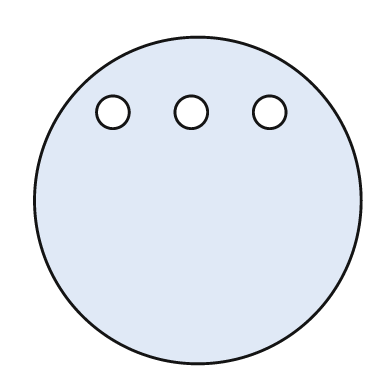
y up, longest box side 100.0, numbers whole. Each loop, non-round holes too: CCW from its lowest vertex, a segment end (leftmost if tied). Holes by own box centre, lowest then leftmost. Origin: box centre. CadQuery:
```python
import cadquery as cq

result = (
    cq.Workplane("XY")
    .moveTo(0.0, 0.0)
    .circle(50.0)
    .moveTo(-26.0, 27.0)
    .circle(5.0)
    .moveTo(-2.0, 27.0)
    .circle(5.0)
    .moveTo(22.0, 27.0)
    .circle(5.0)
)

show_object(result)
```